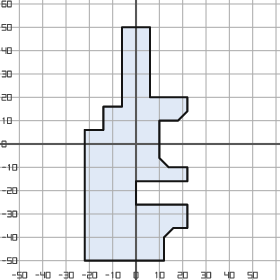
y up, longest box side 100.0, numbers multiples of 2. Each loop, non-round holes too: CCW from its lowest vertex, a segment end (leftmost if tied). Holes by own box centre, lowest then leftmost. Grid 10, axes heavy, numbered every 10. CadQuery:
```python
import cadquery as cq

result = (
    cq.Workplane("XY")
    .moveTo(-22.0, -50.0)
    .lineTo(12.0, -50.0)
    .lineTo(12.0, -40.0)
    .lineTo(16.0, -36.0)
    .lineTo(22.0, -36.0)
    .lineTo(22.0, -26.0)
    .lineTo(0.0, -26.0)
    .lineTo(0.0, -16.0)
    .lineTo(22.0, -16.0)
    .lineTo(22.0, -10.0)
    .lineTo(14.0, -10.0)
    .lineTo(10.0, -6.0)
    .lineTo(10.0, 10.0)
    .lineTo(18.0, 10.0)
    .lineTo(22.0, 14.0)
    .lineTo(22.0, 20.0)
    .lineTo(6.0, 20.0)
    .lineTo(6.0, 50.0)
    .lineTo(-6.0, 50.0)
    .lineTo(-6.0, 16.0)
    .lineTo(-14.0, 16.0)
    .lineTo(-14.0, 6.0)
    .lineTo(-22.0, 6.0)
    .close()
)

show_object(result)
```